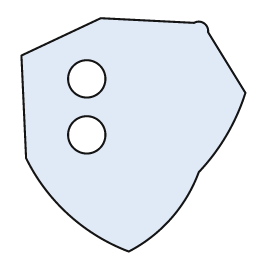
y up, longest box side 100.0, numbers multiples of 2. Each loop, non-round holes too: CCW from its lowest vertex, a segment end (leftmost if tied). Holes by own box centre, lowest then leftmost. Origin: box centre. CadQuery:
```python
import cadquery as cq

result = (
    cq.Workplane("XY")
    .moveTo(-2.0, -50.0)
    .threePointArc((16.0, -36.0), (28.0, -16.0))
    .threePointArc((40.0, 0.0), (48.0, 18.0))
    .lineTo(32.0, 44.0)
    .threePointArc((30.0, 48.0), (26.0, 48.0))
    .lineTo(-14.0, 50.0)
    .lineTo(-48.0, 34.0)
    .lineTo(-46.0, -10.0)
    .threePointArc((-28.0, -34.0), (-2.0, -50.0))
    .close()
    .moveTo(-20.0, 0.0)
    .circle(8.0)
    .moveTo(-20.0, 24.0)
    .circle(8.0)
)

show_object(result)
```